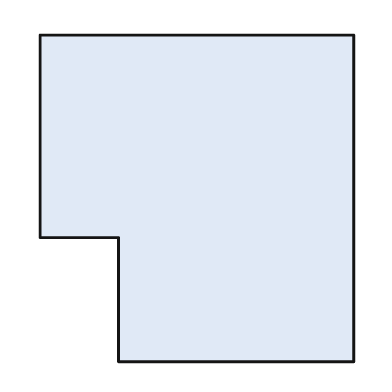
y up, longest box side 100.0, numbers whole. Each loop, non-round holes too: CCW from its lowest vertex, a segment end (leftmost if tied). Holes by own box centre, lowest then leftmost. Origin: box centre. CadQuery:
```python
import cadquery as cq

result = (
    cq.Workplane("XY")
    .moveTo(-24.0, -50.0)
    .lineTo(48.0, -50.0)
    .lineTo(48.0, 50.0)
    .lineTo(-48.0, 50.0)
    .lineTo(-48.0, -12.0)
    .lineTo(-24.0, -12.0)
    .close()
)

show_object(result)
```